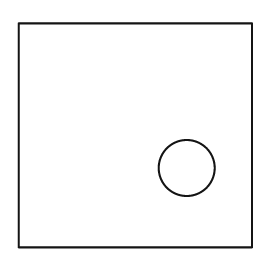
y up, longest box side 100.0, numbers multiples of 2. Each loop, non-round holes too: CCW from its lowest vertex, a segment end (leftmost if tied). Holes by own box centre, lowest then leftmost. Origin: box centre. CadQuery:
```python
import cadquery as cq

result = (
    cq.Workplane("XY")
    .moveTo(-50.0, -48.0)
    .lineTo(50.0, -48.0)
    .lineTo(50.0, 48.0)
    .lineTo(-50.0, 48.0)
    .close()
    .moveTo(22.0, -14.0)
    .circle(12.0)
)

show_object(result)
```